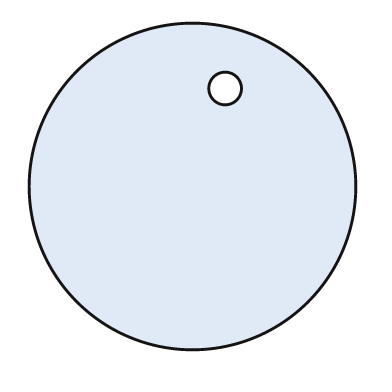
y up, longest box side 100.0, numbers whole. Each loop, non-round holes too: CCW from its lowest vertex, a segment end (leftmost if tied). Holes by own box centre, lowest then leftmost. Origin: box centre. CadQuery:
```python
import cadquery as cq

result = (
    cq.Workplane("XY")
    .moveTo(0.0, 0.0)
    .circle(50.0)
    .moveTo(10.0, 30.0)
    .circle(5.0)
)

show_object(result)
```